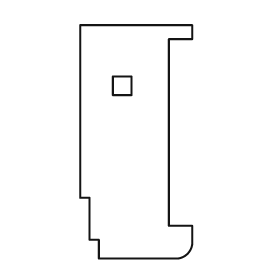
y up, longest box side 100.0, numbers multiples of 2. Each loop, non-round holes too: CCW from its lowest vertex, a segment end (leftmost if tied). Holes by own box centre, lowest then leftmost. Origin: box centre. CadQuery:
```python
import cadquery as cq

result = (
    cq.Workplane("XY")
    .moveTo(-16.0, -50.0)
    .lineTo(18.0, -50.0)
    .threePointArc((22.0, -48.0), (24.0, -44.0))
    .lineTo(24.0, -36.0)
    .lineTo(14.0, -36.0)
    .lineTo(14.0, 44.0)
    .lineTo(24.0, 44.0)
    .lineTo(24.0, 50.0)
    .lineTo(-24.0, 50.0)
    .lineTo(-24.0, -24.0)
    .lineTo(-20.0, -24.0)
    .lineTo(-20.0, -42.0)
    .lineTo(-16.0, -42.0)
    .close()
    .moveTo(-10.0, 20.0)
    .lineTo(-2.0, 20.0)
    .lineTo(-2.0, 28.0)
    .lineTo(-10.0, 28.0)
    .close()
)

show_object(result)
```